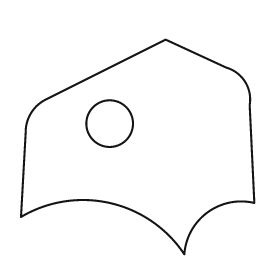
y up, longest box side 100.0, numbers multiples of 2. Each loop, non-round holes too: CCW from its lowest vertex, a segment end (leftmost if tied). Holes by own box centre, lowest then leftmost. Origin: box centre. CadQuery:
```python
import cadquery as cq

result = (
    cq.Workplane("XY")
    .moveTo(20.0, -46.0)
    .threePointArc((30.0, -28.0), (50.0, -24.0))
    .lineTo(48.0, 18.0)
    .threePointArc((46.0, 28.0), (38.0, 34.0))
    .lineTo(12.0, 46.0)
    .lineTo(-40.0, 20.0)
    .threePointArc((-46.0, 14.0), (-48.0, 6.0))
    .lineTo(-50.0, -30.0)
    .threePointArc((-12.0, -24.0), (20.0, -46.0))
    .close()
    .moveTo(-12.0, 10.0)
    .circle(10.0)
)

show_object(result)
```